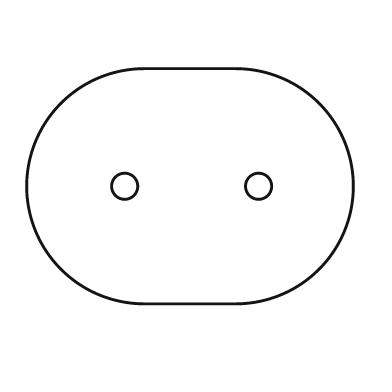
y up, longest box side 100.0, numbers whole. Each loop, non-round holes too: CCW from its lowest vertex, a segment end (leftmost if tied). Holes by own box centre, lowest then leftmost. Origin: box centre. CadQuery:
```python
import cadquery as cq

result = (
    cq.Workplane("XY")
    .moveTo(-14.0, -36.0)
    .lineTo(14.0, -36.0)
    .threePointArc((50.0, 0.0), (14.0, 36.0))
    .lineTo(-14.0, 36.0)
    .threePointArc((-50.0, 0.0), (-14.0, -36.0))
    .close()
    .moveTo(-20.0, 0.0)
    .circle(4.0)
    .moveTo(21.0, 0.0)
    .circle(4.0)
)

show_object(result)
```